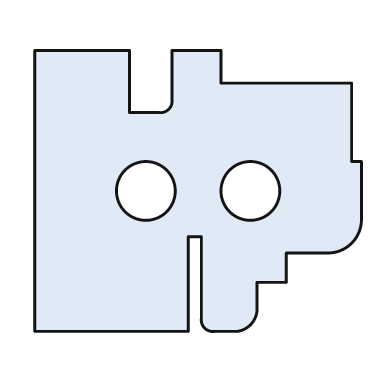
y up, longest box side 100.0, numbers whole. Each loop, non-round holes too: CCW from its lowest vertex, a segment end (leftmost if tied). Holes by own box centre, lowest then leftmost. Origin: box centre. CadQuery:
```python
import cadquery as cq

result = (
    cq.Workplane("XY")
    .moveTo(-50.0, -43.0)
    .lineTo(-3.0, -43.0)
    .lineTo(-3.0, -14.0)
    .lineTo(1.0, -14.0)
    .lineTo(1.0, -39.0)
    .threePointArc((2.0, -42.0), (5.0, -43.0))
    .lineTo(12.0, -43.0)
    .threePointArc((16.0, -41.0), (18.0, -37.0))
    .lineTo(18.0, -28.0)
    .lineTo(27.0, -28.0)
    .lineTo(27.0, -19.0)
    .lineTo(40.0, -19.0)
    .threePointArc((47.0, -16.0), (50.0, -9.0))
    .lineTo(50.0, 9.0)
    .lineTo(47.0, 9.0)
    .lineTo(47.0, 33.0)
    .lineTo(7.0, 33.0)
    .lineTo(7.0, 43.0)
    .lineTo(-8.0, 43.0)
    .lineTo(-8.0, 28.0)
    .threePointArc((-9.0, 25.0), (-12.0, 24.0))
    .lineTo(-21.0, 24.0)
    .lineTo(-21.0, 43.0)
    .lineTo(-50.0, 43.0)
    .close()
    .moveTo(-16.0, 0.0)
    .circle(9.0)
    .moveTo(16.0, 0.0)
    .circle(9.0)
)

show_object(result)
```